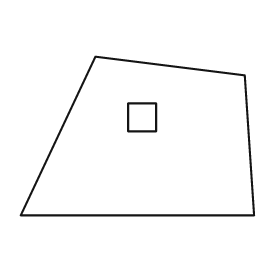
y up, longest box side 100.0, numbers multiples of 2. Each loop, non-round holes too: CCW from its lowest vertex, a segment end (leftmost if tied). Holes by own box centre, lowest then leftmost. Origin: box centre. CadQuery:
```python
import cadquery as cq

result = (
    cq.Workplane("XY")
    .moveTo(-50.0, -34.0)
    .lineTo(50.0, -34.0)
    .lineTo(46.0, 26.0)
    .lineTo(-18.0, 34.0)
    .close()
    .moveTo(-4.0, 2.0)
    .lineTo(8.0, 2.0)
    .lineTo(8.0, 14.0)
    .lineTo(-4.0, 14.0)
    .close()
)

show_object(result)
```